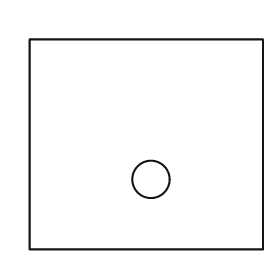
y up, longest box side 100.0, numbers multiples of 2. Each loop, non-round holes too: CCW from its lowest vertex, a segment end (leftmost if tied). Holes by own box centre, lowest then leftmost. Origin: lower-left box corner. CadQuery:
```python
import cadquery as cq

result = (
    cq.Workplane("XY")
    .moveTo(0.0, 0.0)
    .lineTo(100.0, 0.0)
    .lineTo(100.0, 90.0)
    .lineTo(0.0, 90.0)
    .close()
    .moveTo(52.0, 30.0)
    .circle(8.0)
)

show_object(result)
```